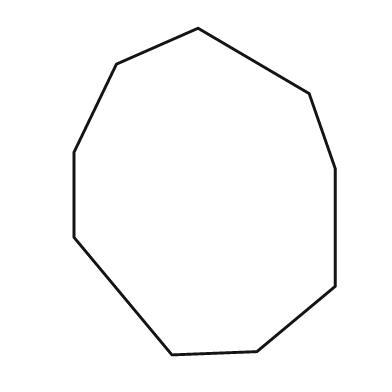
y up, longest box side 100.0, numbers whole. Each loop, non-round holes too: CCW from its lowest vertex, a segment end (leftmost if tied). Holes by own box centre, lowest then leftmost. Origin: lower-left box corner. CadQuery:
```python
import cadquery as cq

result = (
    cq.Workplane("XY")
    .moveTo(30.0, 0.0)
    .lineTo(56.0, 1.0)
    .lineTo(80.0, 21.0)
    .lineTo(80.0, 57.0)
    .lineTo(72.0, 80.0)
    .lineTo(38.0, 100.0)
    .lineTo(13.0, 89.0)
    .lineTo(0.0, 62.0)
    .lineTo(0.0, 36.0)
    .close()
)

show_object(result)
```